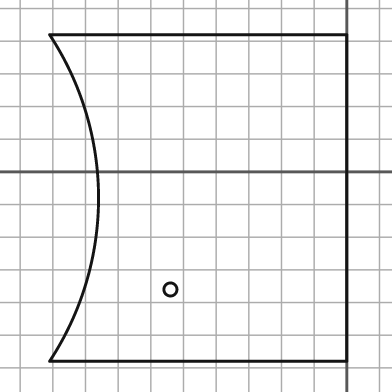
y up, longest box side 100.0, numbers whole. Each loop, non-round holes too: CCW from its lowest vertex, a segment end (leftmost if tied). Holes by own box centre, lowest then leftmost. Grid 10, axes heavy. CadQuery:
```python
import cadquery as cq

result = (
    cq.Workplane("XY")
    .moveTo(-91.0, -58.0)
    .lineTo(0.0, -58.0)
    .lineTo(0.0, 42.0)
    .lineTo(-91.0, 42.0)
    .threePointArc((-76.0, -8.0), (-91.0, -58.0))
    .close()
    .moveTo(-54.0, -36.0)
    .circle(2.0)
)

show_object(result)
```